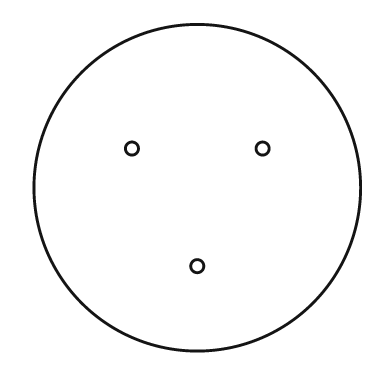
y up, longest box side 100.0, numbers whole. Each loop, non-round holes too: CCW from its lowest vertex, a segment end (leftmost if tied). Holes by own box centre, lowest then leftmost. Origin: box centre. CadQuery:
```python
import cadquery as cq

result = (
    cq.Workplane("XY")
    .moveTo(0.0, 0.0)
    .circle(50.0)
    .moveTo(0.0, -24.0)
    .circle(2.0)
    .moveTo(-20.0, 12.0)
    .circle(2.0)
    .moveTo(20.0, 12.0)
    .circle(2.0)
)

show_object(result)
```